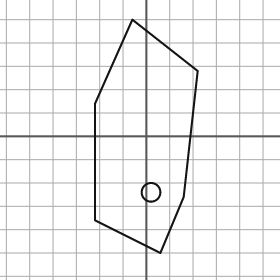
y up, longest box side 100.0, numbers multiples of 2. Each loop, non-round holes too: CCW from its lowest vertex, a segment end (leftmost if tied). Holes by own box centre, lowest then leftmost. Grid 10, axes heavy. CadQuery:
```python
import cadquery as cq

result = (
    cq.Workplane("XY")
    .moveTo(6.0, -50.0)
    .lineTo(16.0, -26.0)
    .lineTo(22.0, 28.0)
    .lineTo(-6.0, 50.0)
    .lineTo(-22.0, 14.0)
    .lineTo(-22.0, -36.0)
    .close()
    .moveTo(2.0, -24.0)
    .circle(4.0)
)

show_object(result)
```